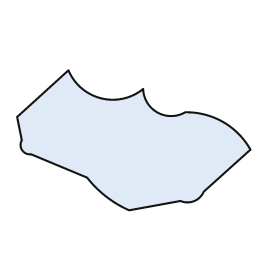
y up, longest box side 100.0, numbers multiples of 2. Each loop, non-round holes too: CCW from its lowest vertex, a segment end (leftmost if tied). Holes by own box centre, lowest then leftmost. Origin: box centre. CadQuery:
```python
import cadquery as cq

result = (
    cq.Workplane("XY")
    .moveTo(-2.0, -30.0)
    .lineTo(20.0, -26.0)
    .threePointArc((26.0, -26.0), (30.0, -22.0))
    .lineTo(50.0, -4.0)
    .threePointArc((38.0, 8.0), (22.0, 12.0))
    .threePointArc((10.0, 12.0), (4.0, 22.0))
    .threePointArc((-14.0, 18.0), (-28.0, 30.0))
    .lineTo(-50.0, 10.0)
    .lineTo(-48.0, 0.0)
    .threePointArc((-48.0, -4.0), (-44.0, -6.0))
    .lineTo(-20.0, -16.0)
    .threePointArc((-12.0, -24.0), (-2.0, -30.0))
    .close()
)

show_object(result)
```